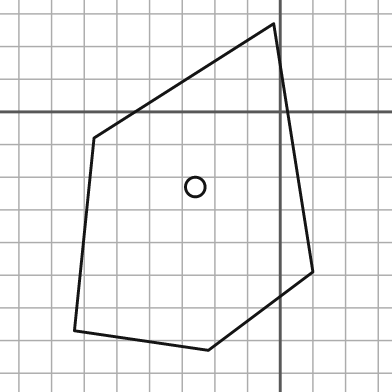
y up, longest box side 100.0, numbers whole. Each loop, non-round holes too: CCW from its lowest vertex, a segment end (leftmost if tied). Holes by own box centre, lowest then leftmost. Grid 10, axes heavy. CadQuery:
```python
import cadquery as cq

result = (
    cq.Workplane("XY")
    .moveTo(-22.0, -73.0)
    .lineTo(10.0, -49.0)
    .lineTo(-2.0, 27.0)
    .lineTo(-57.0, -8.0)
    .lineTo(-63.0, -67.0)
    .close()
    .moveTo(-26.0, -23.0)
    .circle(3.0)
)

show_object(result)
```